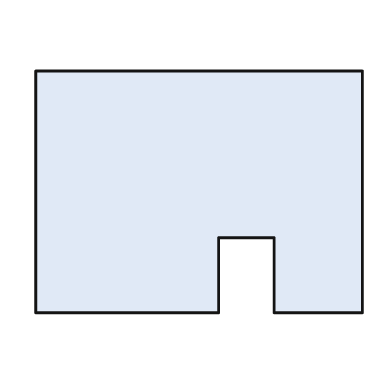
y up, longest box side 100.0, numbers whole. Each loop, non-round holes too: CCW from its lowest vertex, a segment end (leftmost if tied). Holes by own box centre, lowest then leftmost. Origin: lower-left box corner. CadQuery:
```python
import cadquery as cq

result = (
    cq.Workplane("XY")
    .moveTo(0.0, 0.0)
    .lineTo(56.0, 0.0)
    .lineTo(56.0, 23.0)
    .lineTo(73.0, 23.0)
    .lineTo(73.0, 0.0)
    .lineTo(100.0, 0.0)
    .lineTo(100.0, 74.0)
    .lineTo(0.0, 74.0)
    .close()
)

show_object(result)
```